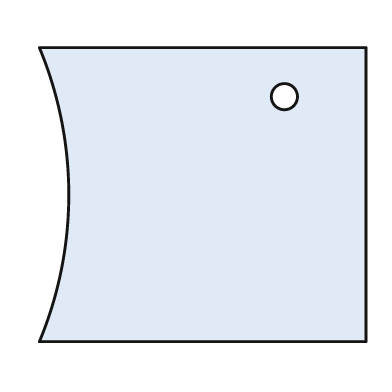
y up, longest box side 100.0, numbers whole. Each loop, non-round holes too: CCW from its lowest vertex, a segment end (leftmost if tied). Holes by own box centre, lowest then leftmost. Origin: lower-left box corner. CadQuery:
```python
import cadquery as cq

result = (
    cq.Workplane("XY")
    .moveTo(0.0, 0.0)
    .lineTo(100.0, 0.0)
    .lineTo(100.0, 90.0)
    .lineTo(0.0, 90.0)
    .threePointArc((9.0, 45.0), (0.0, 0.0))
    .close()
    .moveTo(75.0, 75.0)
    .circle(4.0)
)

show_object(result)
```